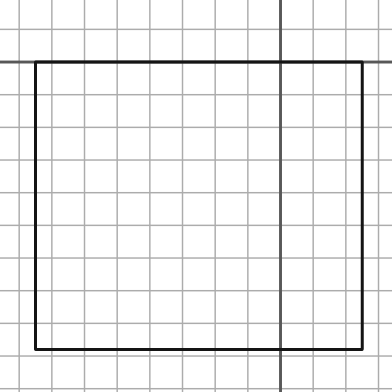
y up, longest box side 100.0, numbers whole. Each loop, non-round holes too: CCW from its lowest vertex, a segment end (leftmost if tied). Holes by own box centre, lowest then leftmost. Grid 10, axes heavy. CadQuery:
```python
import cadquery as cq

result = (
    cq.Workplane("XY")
    .moveTo(-75.0, -88.0)
    .lineTo(25.0, -88.0)
    .lineTo(25.0, 0.0)
    .lineTo(-75.0, 0.0)
    .close()
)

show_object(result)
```